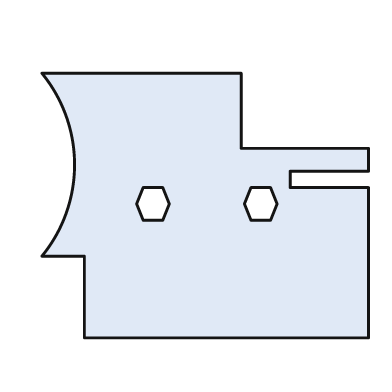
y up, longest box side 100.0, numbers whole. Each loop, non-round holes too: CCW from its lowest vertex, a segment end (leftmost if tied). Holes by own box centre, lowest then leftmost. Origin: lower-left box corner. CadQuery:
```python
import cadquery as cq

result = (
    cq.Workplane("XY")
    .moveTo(13.0, 0.0)
    .lineTo(100.0, 0.0)
    .lineTo(100.0, 46.0)
    .lineTo(76.0, 46.0)
    .lineTo(76.0, 51.0)
    .lineTo(100.0, 51.0)
    .lineTo(100.0, 58.0)
    .lineTo(61.0, 58.0)
    .lineTo(61.0, 81.0)
    .lineTo(0.0, 81.0)
    .threePointArc((10.0, 53.0), (0.0, 25.0))
    .lineTo(13.0, 25.0)
    .close()
    .moveTo(31.0, 36.0)
    .lineTo(37.0, 36.0)
    .lineTo(39.0, 41.0)
    .lineTo(37.0, 46.0)
    .lineTo(31.0, 46.0)
    .lineTo(29.0, 41.0)
    .close()
    .moveTo(64.0, 36.0)
    .lineTo(70.0, 36.0)
    .lineTo(72.0, 41.0)
    .lineTo(70.0, 46.0)
    .lineTo(64.0, 46.0)
    .lineTo(62.0, 41.0)
    .close()
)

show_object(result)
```